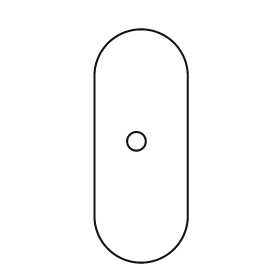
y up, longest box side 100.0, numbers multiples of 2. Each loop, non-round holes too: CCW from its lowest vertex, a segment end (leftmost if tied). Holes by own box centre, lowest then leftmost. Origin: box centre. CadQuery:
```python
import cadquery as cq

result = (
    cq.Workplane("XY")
    .moveTo(-20.0, -30.0)
    .threePointArc((0.0, -50.0), (20.0, -30.0))
    .lineTo(20.0, 30.0)
    .threePointArc((0.0, 50.0), (-20.0, 30.0))
    .close()
    .moveTo(-2.0, 2.0)
    .circle(4.0)
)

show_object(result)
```